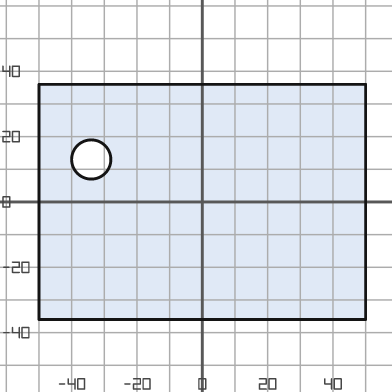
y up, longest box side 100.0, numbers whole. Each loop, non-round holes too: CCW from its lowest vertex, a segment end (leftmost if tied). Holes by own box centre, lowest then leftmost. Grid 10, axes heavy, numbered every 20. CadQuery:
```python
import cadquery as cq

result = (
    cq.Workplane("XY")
    .moveTo(-50.0, -36.0)
    .lineTo(50.0, -36.0)
    .lineTo(50.0, 36.0)
    .lineTo(-50.0, 36.0)
    .close()
    .moveTo(-34.0, 13.0)
    .circle(6.0)
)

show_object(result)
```